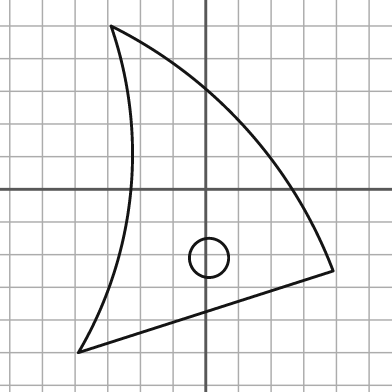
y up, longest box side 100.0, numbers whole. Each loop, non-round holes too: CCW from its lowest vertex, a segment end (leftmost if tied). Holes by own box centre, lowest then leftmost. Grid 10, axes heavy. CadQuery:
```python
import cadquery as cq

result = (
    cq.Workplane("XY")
    .moveTo(-39.0, -50.0)
    .lineTo(39.0, -25.0)
    .threePointArc((12.0, 19.0), (-29.0, 50.0))
    .threePointArc((-23.0, -1.0), (-39.0, -50.0))
    .close()
    .moveTo(1.0, -21.0)
    .circle(6.0)
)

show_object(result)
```